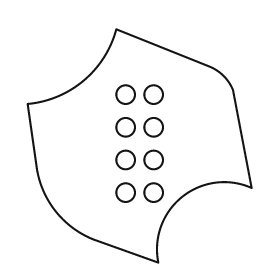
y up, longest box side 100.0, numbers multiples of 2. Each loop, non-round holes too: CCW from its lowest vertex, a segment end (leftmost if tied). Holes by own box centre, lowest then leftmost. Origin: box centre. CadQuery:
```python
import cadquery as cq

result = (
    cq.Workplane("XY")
    .moveTo(8.0, -50.0)
    .threePointArc((18.0, -22.0), (48.0, -18.0))
    .lineTo(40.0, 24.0)
    .threePointArc((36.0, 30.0), (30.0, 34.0))
    .lineTo(-10.0, 50.0)
    .threePointArc((-24.0, 28.0), (-48.0, 18.0))
    .lineTo(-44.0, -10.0)
    .threePointArc((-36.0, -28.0), (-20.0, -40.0))
    .close()
    .moveTo(-6.0, -20.0)
    .circle(4.0)
    .moveTo(6.0, -20.0)
    .circle(4.0)
    .moveTo(-6.0, -6.0)
    .circle(4.0)
    .moveTo(6.0, -6.0)
    .circle(4.0)
    .moveTo(-6.0, 8.0)
    .circle(4.0)
    .moveTo(6.0, 8.0)
    .circle(4.0)
    .moveTo(-6.0, 22.0)
    .circle(4.0)
    .moveTo(6.0, 22.0)
    .circle(4.0)
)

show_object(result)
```